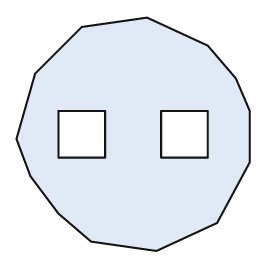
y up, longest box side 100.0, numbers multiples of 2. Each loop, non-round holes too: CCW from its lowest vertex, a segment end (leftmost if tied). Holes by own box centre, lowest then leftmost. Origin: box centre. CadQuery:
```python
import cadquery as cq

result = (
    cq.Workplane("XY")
    .moveTo(10.0, -50.0)
    .lineTo(36.0, -38.0)
    .lineTo(50.0, -12.0)
    .lineTo(50.0, 10.0)
    .lineTo(44.0, 24.0)
    .lineTo(32.0, 38.0)
    .lineTo(6.0, 50.0)
    .lineTo(-22.0, 46.0)
    .lineTo(-42.0, 26.0)
    .lineTo(-50.0, -2.0)
    .lineTo(-44.0, -18.0)
    .lineTo(-32.0, -34.0)
    .lineTo(-18.0, -46.0)
    .close()
    .moveTo(-32.0, -10.0)
    .lineTo(-12.0, -10.0)
    .lineTo(-12.0, 10.0)
    .lineTo(-32.0, 10.0)
    .close()
    .moveTo(12.0, -10.0)
    .lineTo(32.0, -10.0)
    .lineTo(32.0, 10.0)
    .lineTo(12.0, 10.0)
    .close()
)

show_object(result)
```